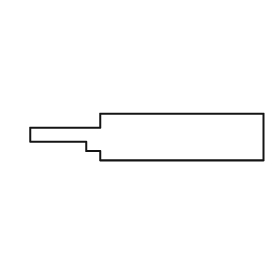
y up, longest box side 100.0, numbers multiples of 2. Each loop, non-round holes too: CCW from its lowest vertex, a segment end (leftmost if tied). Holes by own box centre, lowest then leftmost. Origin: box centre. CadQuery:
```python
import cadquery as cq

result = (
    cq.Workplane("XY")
    .moveTo(-20.0, -10.0)
    .lineTo(50.0, -10.0)
    .lineTo(50.0, 10.0)
    .lineTo(-20.0, 10.0)
    .lineTo(-20.0, 4.0)
    .lineTo(-50.0, 4.0)
    .lineTo(-50.0, -2.0)
    .lineTo(-26.0, -2.0)
    .lineTo(-26.0, -6.0)
    .lineTo(-20.0, -6.0)
    .close()
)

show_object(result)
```